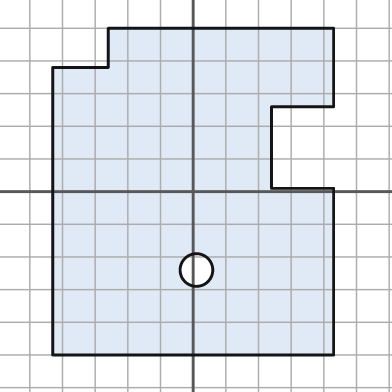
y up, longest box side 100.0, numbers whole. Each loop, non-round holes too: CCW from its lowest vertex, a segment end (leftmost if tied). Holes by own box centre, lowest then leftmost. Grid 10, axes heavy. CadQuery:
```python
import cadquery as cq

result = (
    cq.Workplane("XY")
    .moveTo(-43.0, -50.0)
    .lineTo(43.0, -50.0)
    .lineTo(43.0, 1.0)
    .lineTo(24.0, 1.0)
    .lineTo(24.0, 26.0)
    .lineTo(43.0, 26.0)
    .lineTo(43.0, 50.0)
    .lineTo(-26.0, 50.0)
    .lineTo(-26.0, 38.0)
    .lineTo(-43.0, 38.0)
    .close()
    .moveTo(1.0, -24.0)
    .circle(5.0)
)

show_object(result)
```